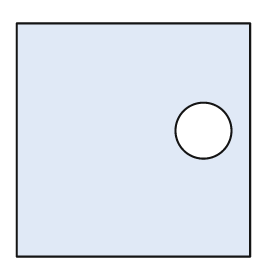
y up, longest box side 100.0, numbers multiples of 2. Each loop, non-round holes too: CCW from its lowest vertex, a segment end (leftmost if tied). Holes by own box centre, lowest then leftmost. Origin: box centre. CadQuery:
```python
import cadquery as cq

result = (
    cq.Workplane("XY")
    .moveTo(-50.0, -50.0)
    .lineTo(50.0, -50.0)
    .lineTo(50.0, 50.0)
    .lineTo(-50.0, 50.0)
    .close()
    .moveTo(30.0, 4.0)
    .circle(12.0)
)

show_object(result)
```